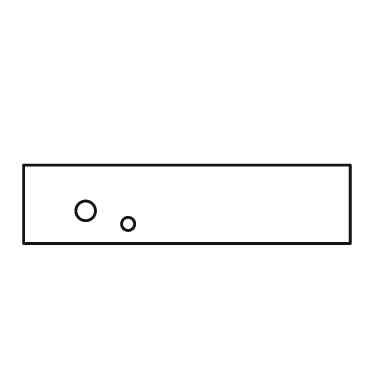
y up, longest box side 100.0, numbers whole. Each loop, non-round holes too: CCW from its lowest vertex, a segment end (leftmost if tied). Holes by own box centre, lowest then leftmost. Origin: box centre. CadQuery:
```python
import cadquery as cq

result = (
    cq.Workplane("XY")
    .moveTo(-50.0, -12.0)
    .lineTo(50.0, -12.0)
    .lineTo(50.0, 12.0)
    .lineTo(-50.0, 12.0)
    .close()
    .moveTo(-18.0, -6.0)
    .circle(2.0)
    .moveTo(-31.0, -2.0)
    .circle(3.0)
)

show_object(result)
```